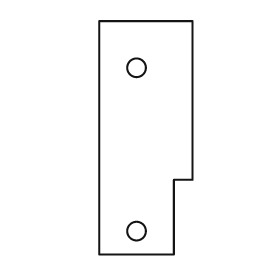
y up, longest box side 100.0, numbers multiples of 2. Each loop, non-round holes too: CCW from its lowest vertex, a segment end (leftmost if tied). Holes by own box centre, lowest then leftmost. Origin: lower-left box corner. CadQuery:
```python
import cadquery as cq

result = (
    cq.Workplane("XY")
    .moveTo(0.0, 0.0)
    .lineTo(32.0, 0.0)
    .lineTo(32.0, 32.0)
    .lineTo(40.0, 32.0)
    .lineTo(40.0, 100.0)
    .lineTo(0.0, 100.0)
    .close()
    .moveTo(16.0, 10.0)
    .circle(4.0)
    .moveTo(16.0, 80.0)
    .circle(4.0)
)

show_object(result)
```